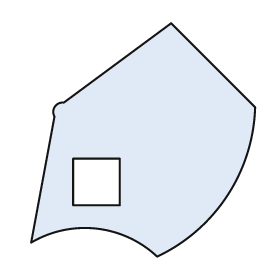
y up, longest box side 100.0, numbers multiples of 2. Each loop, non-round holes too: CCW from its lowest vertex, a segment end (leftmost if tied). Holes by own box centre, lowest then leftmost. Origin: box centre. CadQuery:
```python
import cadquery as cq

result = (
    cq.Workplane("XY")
    .moveTo(6.0, -50.0)
    .threePointArc((36.0, -24.0), (48.0, 14.0))
    .lineTo(12.0, 50.0)
    .lineTo(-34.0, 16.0)
    .threePointArc((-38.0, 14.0), (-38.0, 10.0))
    .lineTo(-48.0, -44.0)
    .threePointArc((-20.0, -38.0), (6.0, -50.0))
    .close()
    .moveTo(-30.0, -28.0)
    .lineTo(-10.0, -28.0)
    .lineTo(-10.0, -8.0)
    .lineTo(-30.0, -8.0)
    .close()
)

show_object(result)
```